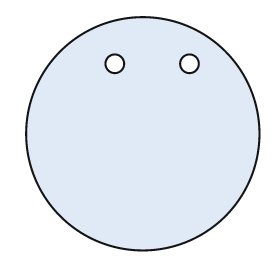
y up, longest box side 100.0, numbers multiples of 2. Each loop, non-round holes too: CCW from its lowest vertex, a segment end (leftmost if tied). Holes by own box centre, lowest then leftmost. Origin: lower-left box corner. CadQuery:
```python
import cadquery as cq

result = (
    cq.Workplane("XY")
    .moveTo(50.0, 50.0)
    .circle(50.0)
    .moveTo(38.0, 80.0)
    .circle(4.0)
    .moveTo(70.0, 80.0)
    .circle(4.0)
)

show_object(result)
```